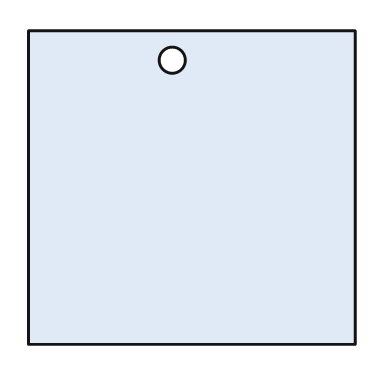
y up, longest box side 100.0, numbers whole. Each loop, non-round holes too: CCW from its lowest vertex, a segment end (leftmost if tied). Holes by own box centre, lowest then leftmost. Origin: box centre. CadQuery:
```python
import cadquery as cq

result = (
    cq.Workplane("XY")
    .moveTo(-50.0, -48.0)
    .lineTo(50.0, -48.0)
    .lineTo(50.0, 48.0)
    .lineTo(-50.0, 48.0)
    .close()
    .moveTo(-6.0, 39.0)
    .circle(4.0)
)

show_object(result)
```